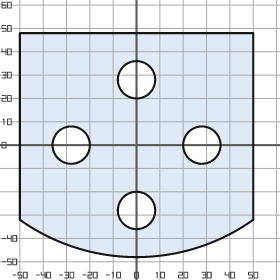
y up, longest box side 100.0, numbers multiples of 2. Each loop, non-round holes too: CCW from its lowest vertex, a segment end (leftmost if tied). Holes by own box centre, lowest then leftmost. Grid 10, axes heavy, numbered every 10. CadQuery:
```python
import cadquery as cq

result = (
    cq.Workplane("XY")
    .moveTo(-50.0, -32.0)
    .threePointArc((0.0, -48.0), (50.0, -32.0))
    .lineTo(50.0, 48.0)
    .lineTo(-50.0, 48.0)
    .close()
    .moveTo(0.0, -28.0)
    .circle(8.0)
    .moveTo(-28.0, 0.0)
    .circle(8.0)
    .moveTo(28.0, 0.0)
    .circle(8.0)
    .moveTo(0.0, 28.0)
    .circle(8.0)
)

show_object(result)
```